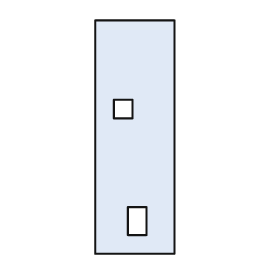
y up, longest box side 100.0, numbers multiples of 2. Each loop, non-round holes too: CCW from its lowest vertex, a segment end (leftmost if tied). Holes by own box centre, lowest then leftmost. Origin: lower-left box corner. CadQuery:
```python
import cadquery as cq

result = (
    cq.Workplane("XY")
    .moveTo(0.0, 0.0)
    .lineTo(34.0, 0.0)
    .lineTo(34.0, 100.0)
    .lineTo(0.0, 100.0)
    .close()
    .moveTo(14.0, 8.0)
    .lineTo(22.0, 8.0)
    .lineTo(22.0, 20.0)
    .lineTo(14.0, 20.0)
    .close()
    .moveTo(8.0, 58.0)
    .lineTo(16.0, 58.0)
    .lineTo(16.0, 66.0)
    .lineTo(8.0, 66.0)
    .close()
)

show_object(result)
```